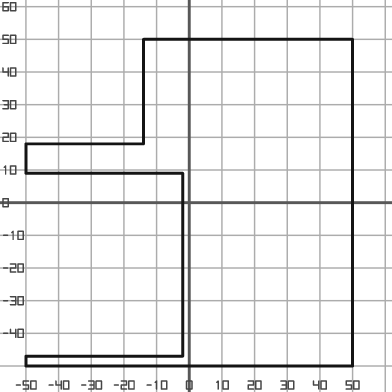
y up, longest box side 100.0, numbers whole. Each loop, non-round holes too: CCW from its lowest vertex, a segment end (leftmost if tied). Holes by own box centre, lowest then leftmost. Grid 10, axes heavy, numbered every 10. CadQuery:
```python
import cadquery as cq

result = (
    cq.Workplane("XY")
    .moveTo(-50.0, -50.0)
    .lineTo(50.0, -50.0)
    .lineTo(50.0, 50.0)
    .lineTo(-14.0, 50.0)
    .lineTo(-14.0, 18.0)
    .lineTo(-50.0, 18.0)
    .lineTo(-50.0, 9.0)
    .lineTo(-2.0, 9.0)
    .lineTo(-2.0, -47.0)
    .lineTo(-50.0, -47.0)
    .close()
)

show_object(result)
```